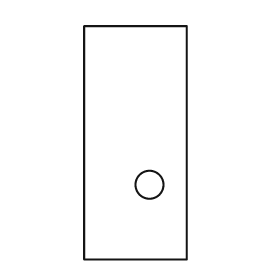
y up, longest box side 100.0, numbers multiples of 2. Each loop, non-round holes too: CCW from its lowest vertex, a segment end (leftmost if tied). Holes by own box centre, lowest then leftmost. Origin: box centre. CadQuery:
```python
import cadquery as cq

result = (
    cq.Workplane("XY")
    .moveTo(-22.0, -50.0)
    .lineTo(22.0, -50.0)
    .lineTo(22.0, 50.0)
    .lineTo(-22.0, 50.0)
    .close()
    .moveTo(6.0, -18.0)
    .circle(6.0)
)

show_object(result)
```